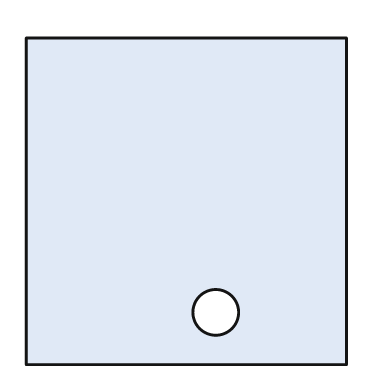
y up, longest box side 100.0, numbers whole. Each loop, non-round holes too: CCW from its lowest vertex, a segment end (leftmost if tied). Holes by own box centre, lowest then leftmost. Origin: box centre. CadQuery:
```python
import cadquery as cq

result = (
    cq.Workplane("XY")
    .moveTo(-49.0, -50.0)
    .lineTo(49.0, -50.0)
    .lineTo(49.0, 50.0)
    .lineTo(-49.0, 50.0)
    .close()
    .moveTo(9.0, -34.0)
    .circle(7.0)
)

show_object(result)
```